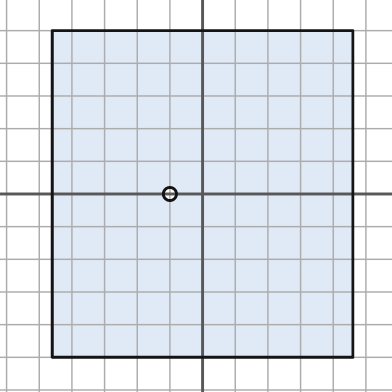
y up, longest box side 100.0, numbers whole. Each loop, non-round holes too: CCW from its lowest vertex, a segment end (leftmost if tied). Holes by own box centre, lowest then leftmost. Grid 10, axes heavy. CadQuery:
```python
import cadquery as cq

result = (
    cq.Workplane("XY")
    .moveTo(-46.0, -50.0)
    .lineTo(46.0, -50.0)
    .lineTo(46.0, 50.0)
    .lineTo(-46.0, 50.0)
    .close()
    .moveTo(-10.0, 0.0)
    .circle(2.0)
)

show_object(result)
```